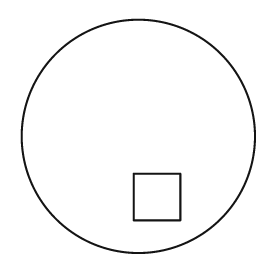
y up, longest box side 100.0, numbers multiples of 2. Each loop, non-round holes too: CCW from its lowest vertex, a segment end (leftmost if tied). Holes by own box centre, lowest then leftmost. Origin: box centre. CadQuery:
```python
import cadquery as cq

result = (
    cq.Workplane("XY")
    .moveTo(0.0, 0.0)
    .circle(50.0)
    .moveTo(-2.0, -36.0)
    .lineTo(18.0, -36.0)
    .lineTo(18.0, -16.0)
    .lineTo(-2.0, -16.0)
    .close()
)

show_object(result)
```